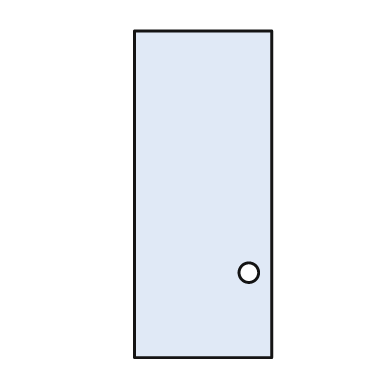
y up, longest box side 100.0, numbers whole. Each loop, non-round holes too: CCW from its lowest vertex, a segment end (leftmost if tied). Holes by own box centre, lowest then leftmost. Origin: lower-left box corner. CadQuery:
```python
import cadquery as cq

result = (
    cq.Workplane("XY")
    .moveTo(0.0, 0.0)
    .lineTo(42.0, 0.0)
    .lineTo(42.0, 100.0)
    .lineTo(0.0, 100.0)
    .close()
    .moveTo(35.0, 26.0)
    .circle(3.0)
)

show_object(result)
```